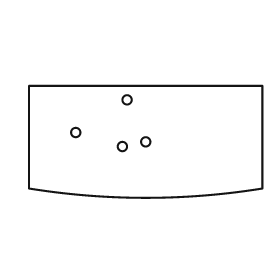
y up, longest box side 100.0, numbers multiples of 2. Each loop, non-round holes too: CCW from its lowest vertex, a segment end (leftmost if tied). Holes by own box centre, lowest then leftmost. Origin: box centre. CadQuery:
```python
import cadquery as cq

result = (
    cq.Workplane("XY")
    .moveTo(-50.0, -20.0)
    .threePointArc((0.0, -24.0), (50.0, -20.0))
    .lineTo(50.0, 24.0)
    .lineTo(-50.0, 24.0)
    .close()
    .moveTo(-10.0, -2.0)
    .circle(2.0)
    .moveTo(0.0, 0.0)
    .circle(2.0)
    .moveTo(-30.0, 4.0)
    .circle(2.0)
    .moveTo(-8.0, 18.0)
    .circle(2.0)
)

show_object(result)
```